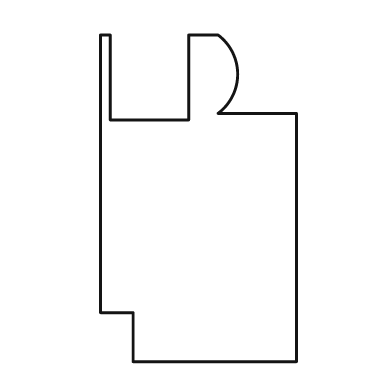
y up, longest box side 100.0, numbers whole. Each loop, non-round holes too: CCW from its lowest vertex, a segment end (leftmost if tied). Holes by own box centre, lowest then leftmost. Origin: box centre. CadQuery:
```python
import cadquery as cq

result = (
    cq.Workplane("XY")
    .moveTo(-20.0, -50.0)
    .lineTo(30.0, -50.0)
    .lineTo(30.0, 26.0)
    .lineTo(6.0, 26.0)
    .threePointArc((12.0, 38.0), (6.0, 50.0))
    .lineTo(-3.0, 50.0)
    .lineTo(-3.0, 24.0)
    .lineTo(-27.0, 24.0)
    .lineTo(-27.0, 50.0)
    .lineTo(-30.0, 50.0)
    .lineTo(-30.0, -35.0)
    .lineTo(-20.0, -35.0)
    .close()
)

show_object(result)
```